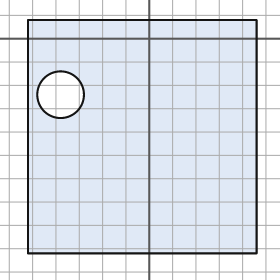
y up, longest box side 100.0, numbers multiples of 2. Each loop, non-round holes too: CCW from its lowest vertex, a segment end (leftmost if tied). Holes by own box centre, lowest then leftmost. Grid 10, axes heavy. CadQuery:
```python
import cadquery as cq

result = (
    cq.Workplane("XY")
    .moveTo(-52.0, -92.0)
    .lineTo(46.0, -92.0)
    .lineTo(46.0, 8.0)
    .lineTo(-52.0, 8.0)
    .close()
    .moveTo(-38.0, -24.0)
    .circle(10.0)
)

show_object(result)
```